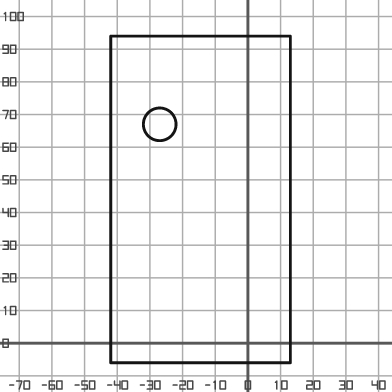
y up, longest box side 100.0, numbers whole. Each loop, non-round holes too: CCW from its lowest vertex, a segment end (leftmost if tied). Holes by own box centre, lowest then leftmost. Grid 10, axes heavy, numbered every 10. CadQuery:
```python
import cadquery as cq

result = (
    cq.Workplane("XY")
    .moveTo(-42.0, -6.0)
    .lineTo(13.0, -6.0)
    .lineTo(13.0, 94.0)
    .lineTo(-42.0, 94.0)
    .close()
    .moveTo(-27.0, 67.0)
    .circle(5.0)
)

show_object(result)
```